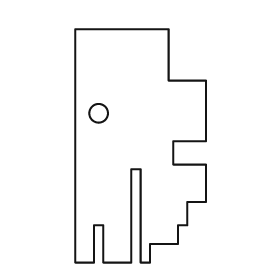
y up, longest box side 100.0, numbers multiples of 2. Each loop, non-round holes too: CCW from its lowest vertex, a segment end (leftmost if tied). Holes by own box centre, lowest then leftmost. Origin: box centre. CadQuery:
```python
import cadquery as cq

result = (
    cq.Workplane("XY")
    .moveTo(-28.0, -50.0)
    .lineTo(-20.0, -50.0)
    .lineTo(-20.0, -34.0)
    .lineTo(-16.0, -34.0)
    .lineTo(-16.0, -50.0)
    .lineTo(-4.0, -50.0)
    .lineTo(-4.0, -10.0)
    .lineTo(0.0, -10.0)
    .lineTo(0.0, -50.0)
    .lineTo(4.0, -50.0)
    .lineTo(4.0, -42.0)
    .lineTo(16.0, -42.0)
    .lineTo(16.0, -34.0)
    .lineTo(20.0, -34.0)
    .lineTo(20.0, -24.0)
    .lineTo(28.0, -24.0)
    .lineTo(28.0, -8.0)
    .lineTo(14.0, -8.0)
    .lineTo(14.0, 2.0)
    .lineTo(28.0, 2.0)
    .lineTo(28.0, 28.0)
    .lineTo(12.0, 28.0)
    .lineTo(12.0, 50.0)
    .lineTo(-28.0, 50.0)
    .close()
    .moveTo(-18.0, 14.0)
    .circle(4.0)
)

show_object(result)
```